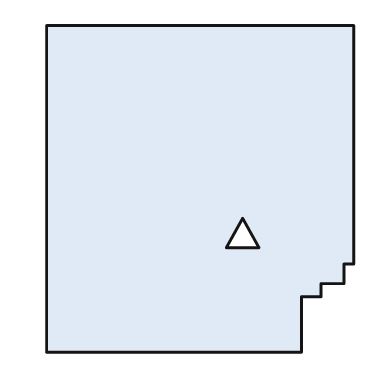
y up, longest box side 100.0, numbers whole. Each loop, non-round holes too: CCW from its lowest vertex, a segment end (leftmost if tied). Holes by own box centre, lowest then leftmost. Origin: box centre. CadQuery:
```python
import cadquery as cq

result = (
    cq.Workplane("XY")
    .moveTo(-47.0, -50.0)
    .lineTo(31.0, -50.0)
    .lineTo(31.0, -33.0)
    .lineTo(37.0, -33.0)
    .lineTo(37.0, -29.0)
    .lineTo(44.0, -29.0)
    .lineTo(44.0, -23.0)
    .lineTo(47.0, -23.0)
    .lineTo(47.0, 50.0)
    .lineTo(-47.0, 50.0)
    .close()
    .moveTo(8.0, -18.0)
    .lineTo(18.0, -18.0)
    .lineTo(13.0, -9.0)
    .close()
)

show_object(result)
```